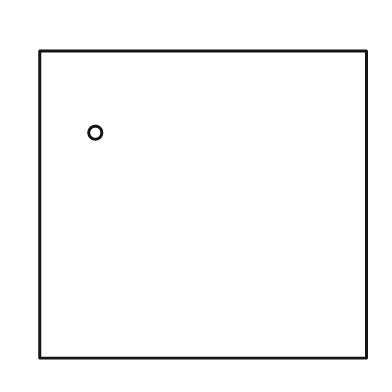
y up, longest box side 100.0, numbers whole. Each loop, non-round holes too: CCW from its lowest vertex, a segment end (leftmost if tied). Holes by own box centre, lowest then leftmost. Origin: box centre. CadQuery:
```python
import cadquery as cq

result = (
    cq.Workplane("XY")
    .moveTo(-50.0, -47.0)
    .lineTo(50.0, -47.0)
    .lineTo(50.0, 47.0)
    .lineTo(-50.0, 47.0)
    .close()
    .moveTo(-33.0, 22.0)
    .circle(2.0)
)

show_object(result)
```